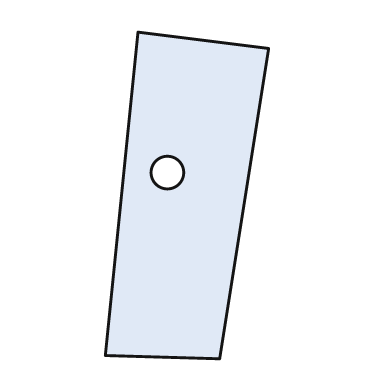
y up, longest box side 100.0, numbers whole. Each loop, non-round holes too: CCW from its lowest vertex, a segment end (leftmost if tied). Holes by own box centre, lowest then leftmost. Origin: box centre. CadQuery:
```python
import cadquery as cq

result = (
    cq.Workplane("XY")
    .moveTo(10.0, -50.0)
    .lineTo(25.0, 45.0)
    .lineTo(-15.0, 50.0)
    .lineTo(-25.0, -49.0)
    .close()
    .moveTo(-6.0, 7.0)
    .circle(5.0)
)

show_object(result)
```